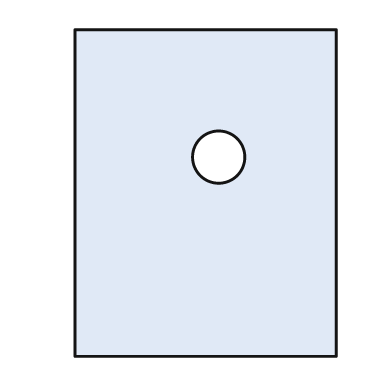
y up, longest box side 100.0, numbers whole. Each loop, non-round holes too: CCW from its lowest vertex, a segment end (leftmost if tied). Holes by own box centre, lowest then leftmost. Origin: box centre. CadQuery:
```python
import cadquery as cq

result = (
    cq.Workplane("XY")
    .moveTo(-40.0, -50.0)
    .lineTo(40.0, -50.0)
    .lineTo(40.0, 50.0)
    .lineTo(-40.0, 50.0)
    .close()
    .moveTo(4.0, 11.0)
    .circle(8.0)
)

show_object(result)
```